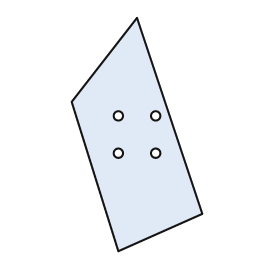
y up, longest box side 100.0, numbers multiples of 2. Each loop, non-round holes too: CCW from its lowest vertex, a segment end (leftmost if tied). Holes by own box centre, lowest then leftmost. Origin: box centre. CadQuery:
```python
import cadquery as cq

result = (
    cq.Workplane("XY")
    .moveTo(-8.0, -50.0)
    .lineTo(28.0, -34.0)
    .lineTo(0.0, 50.0)
    .lineTo(-28.0, 14.0)
    .close()
    .moveTo(-8.0, -8.0)
    .circle(2.0)
    .moveTo(8.0, -8.0)
    .circle(2.0)
    .moveTo(-8.0, 8.0)
    .circle(2.0)
    .moveTo(8.0, 8.0)
    .circle(2.0)
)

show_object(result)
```